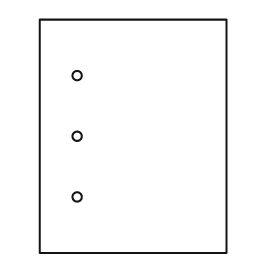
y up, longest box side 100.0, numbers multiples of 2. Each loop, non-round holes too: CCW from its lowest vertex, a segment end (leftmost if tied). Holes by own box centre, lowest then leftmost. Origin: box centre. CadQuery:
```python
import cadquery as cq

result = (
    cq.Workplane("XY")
    .moveTo(-40.0, -50.0)
    .lineTo(40.0, -50.0)
    .lineTo(40.0, 50.0)
    .lineTo(-40.0, 50.0)
    .close()
    .moveTo(-24.0, -26.0)
    .circle(2.0)
    .moveTo(-24.0, 0.0)
    .circle(2.0)
    .moveTo(-24.0, 26.0)
    .circle(2.0)
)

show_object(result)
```